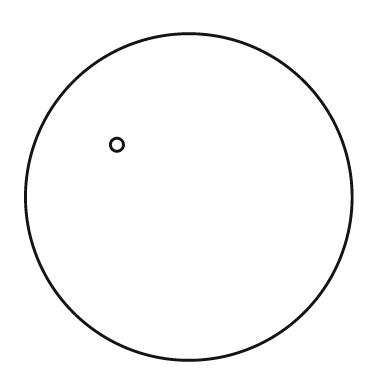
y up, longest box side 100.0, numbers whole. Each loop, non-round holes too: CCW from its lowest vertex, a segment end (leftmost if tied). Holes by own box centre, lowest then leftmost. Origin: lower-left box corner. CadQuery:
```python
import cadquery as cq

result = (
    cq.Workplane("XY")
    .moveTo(50.0, 50.0)
    .circle(50.0)
    .moveTo(28.0, 66.0)
    .circle(2.0)
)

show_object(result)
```